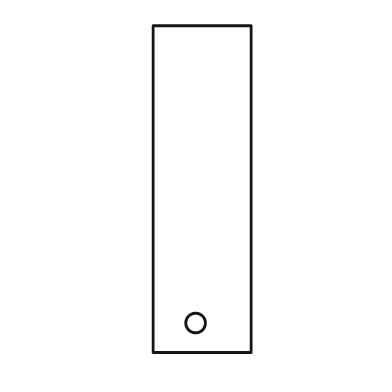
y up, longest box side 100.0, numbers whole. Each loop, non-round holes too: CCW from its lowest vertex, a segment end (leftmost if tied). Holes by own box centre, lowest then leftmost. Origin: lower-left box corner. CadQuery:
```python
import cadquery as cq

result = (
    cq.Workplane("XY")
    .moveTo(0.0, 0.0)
    .lineTo(30.0, 0.0)
    .lineTo(30.0, 100.0)
    .lineTo(0.0, 100.0)
    .close()
    .moveTo(13.0, 9.0)
    .circle(3.0)
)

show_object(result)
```